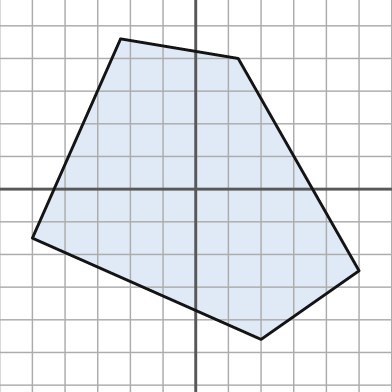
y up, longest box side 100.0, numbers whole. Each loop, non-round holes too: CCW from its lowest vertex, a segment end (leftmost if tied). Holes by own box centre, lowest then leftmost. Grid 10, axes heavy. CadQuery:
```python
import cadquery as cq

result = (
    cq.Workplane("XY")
    .moveTo(20.0, -46.0)
    .lineTo(50.0, -25.0)
    .lineTo(13.0, 40.0)
    .lineTo(-23.0, 46.0)
    .lineTo(-50.0, -15.0)
    .close()
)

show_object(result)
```